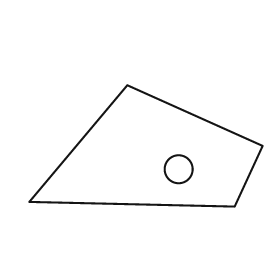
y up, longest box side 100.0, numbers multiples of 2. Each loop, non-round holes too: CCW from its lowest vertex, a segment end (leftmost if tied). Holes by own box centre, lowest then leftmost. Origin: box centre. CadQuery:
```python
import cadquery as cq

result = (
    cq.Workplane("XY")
    .moveTo(38.0, -26.0)
    .lineTo(50.0, 0.0)
    .lineTo(-8.0, 26.0)
    .lineTo(-50.0, -24.0)
    .close()
    .moveTo(14.0, -10.0)
    .circle(6.0)
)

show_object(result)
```